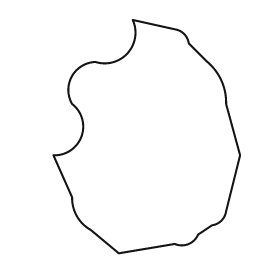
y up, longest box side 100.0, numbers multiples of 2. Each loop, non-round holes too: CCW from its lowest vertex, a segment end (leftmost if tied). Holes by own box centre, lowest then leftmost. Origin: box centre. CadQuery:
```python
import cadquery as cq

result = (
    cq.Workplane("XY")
    .moveTo(-12.0, -50.0)
    .lineTo(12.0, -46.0)
    .threePointArc((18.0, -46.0), (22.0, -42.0))
    .lineTo(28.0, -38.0)
    .threePointArc((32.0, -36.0), (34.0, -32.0))
    .lineTo(40.0, -8.0)
    .lineTo(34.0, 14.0)
    .threePointArc((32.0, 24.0), (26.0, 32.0))
    .lineTo(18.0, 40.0)
    .threePointArc((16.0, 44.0), (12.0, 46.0))
    .lineTo(-6.0, 50.0)
    .threePointArc((-8.0, 36.0), (-22.0, 32.0))
    .threePointArc((-32.0, 26.0), (-32.0, 14.0))
    .threePointArc((-28.0, 0.0), (-40.0, -8.0))
    .lineTo(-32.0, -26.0)
    .threePointArc((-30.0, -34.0), (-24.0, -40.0))
    .close()
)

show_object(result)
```